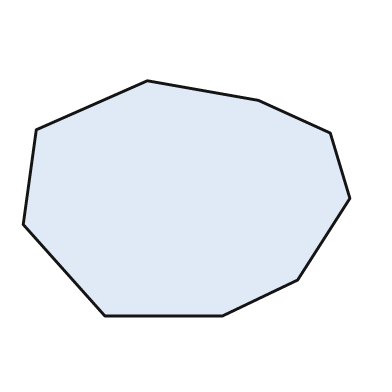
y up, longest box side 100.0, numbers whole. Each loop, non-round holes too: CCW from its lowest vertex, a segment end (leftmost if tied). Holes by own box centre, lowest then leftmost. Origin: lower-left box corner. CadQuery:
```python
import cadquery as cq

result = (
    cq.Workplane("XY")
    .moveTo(25.0, 0.0)
    .lineTo(61.0, 0.0)
    .lineTo(84.0, 11.0)
    .lineTo(100.0, 36.0)
    .lineTo(94.0, 56.0)
    .lineTo(72.0, 66.0)
    .lineTo(38.0, 72.0)
    .lineTo(4.0, 57.0)
    .lineTo(0.0, 28.0)
    .close()
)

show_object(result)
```